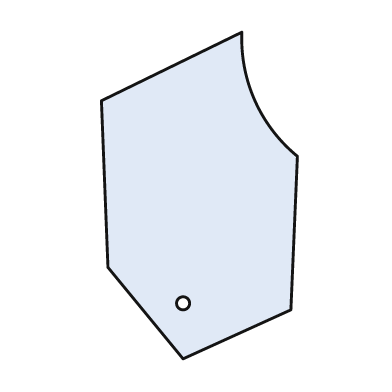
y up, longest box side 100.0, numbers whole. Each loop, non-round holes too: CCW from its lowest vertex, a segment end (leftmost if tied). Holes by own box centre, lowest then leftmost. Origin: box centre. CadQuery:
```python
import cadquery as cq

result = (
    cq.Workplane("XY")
    .moveTo(-5.0, -50.0)
    .lineTo(28.0, -35.0)
    .lineTo(30.0, 12.0)
    .threePointArc((17.0, 29.0), (13.0, 50.0))
    .lineTo(-30.0, 29.0)
    .lineTo(-28.0, -22.0)
    .close()
    .moveTo(-5.0, -33.0)
    .circle(2.0)
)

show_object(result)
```